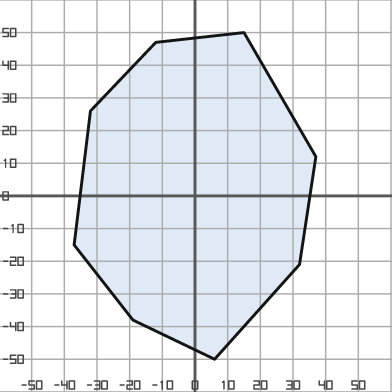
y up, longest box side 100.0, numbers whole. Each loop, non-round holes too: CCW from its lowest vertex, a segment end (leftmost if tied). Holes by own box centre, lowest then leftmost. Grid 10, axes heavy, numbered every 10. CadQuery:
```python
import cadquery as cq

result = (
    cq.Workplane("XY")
    .moveTo(6.0, -50.0)
    .lineTo(32.0, -21.0)
    .lineTo(37.0, 12.0)
    .lineTo(15.0, 50.0)
    .lineTo(-12.0, 47.0)
    .lineTo(-32.0, 26.0)
    .lineTo(-37.0, -15.0)
    .lineTo(-19.0, -38.0)
    .close()
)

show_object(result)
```